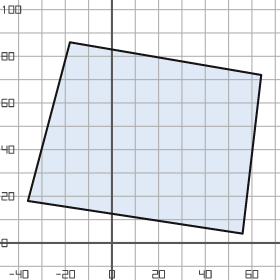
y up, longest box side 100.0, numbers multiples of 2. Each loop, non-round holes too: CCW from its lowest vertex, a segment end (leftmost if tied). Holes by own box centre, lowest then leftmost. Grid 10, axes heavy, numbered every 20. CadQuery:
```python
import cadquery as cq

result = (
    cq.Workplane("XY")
    .moveTo(56.0, 4.0)
    .lineTo(64.0, 72.0)
    .lineTo(-18.0, 86.0)
    .lineTo(-36.0, 18.0)
    .close()
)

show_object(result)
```